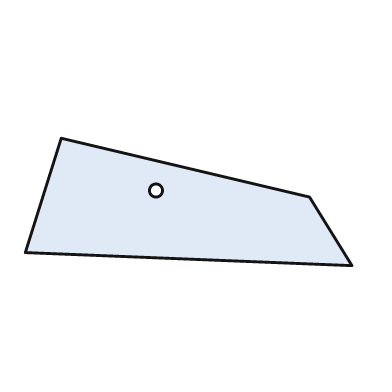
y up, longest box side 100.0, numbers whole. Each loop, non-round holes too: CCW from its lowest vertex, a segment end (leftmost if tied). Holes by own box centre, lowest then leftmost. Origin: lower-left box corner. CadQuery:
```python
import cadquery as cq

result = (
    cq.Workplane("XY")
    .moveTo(100.0, 0.0)
    .lineTo(87.0, 21.0)
    .lineTo(11.0, 39.0)
    .lineTo(0.0, 4.0)
    .close()
    .moveTo(40.0, 23.0)
    .circle(2.0)
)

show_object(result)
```